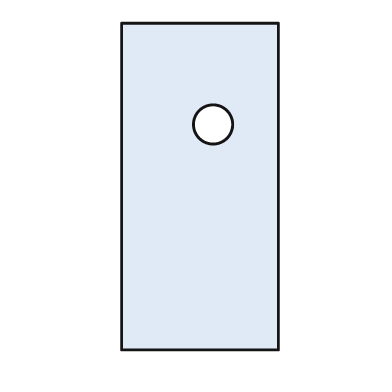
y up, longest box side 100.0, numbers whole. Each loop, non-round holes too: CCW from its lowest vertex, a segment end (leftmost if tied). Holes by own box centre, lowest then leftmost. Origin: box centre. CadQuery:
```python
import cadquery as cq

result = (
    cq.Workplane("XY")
    .moveTo(-24.0, -50.0)
    .lineTo(24.0, -50.0)
    .lineTo(24.0, 50.0)
    .lineTo(-24.0, 50.0)
    .close()
    .moveTo(4.0, 19.0)
    .circle(6.0)
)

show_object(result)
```